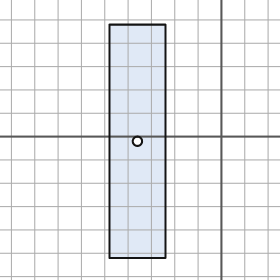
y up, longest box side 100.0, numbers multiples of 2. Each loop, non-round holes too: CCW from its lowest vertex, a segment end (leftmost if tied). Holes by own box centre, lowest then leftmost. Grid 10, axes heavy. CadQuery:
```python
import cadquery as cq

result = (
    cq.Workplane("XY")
    .moveTo(-48.0, -52.0)
    .lineTo(-24.0, -52.0)
    .lineTo(-24.0, 48.0)
    .lineTo(-48.0, 48.0)
    .close()
    .moveTo(-36.0, -2.0)
    .circle(2.0)
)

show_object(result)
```